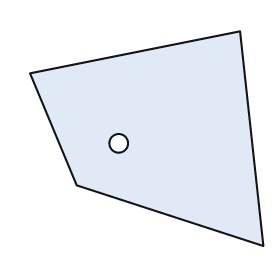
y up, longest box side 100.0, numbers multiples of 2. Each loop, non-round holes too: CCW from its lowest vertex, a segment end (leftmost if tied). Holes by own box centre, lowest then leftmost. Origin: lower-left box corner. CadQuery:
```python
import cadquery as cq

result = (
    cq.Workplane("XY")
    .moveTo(100.0, 0.0)
    .lineTo(90.0, 92.0)
    .lineTo(0.0, 74.0)
    .lineTo(20.0, 26.0)
    .close()
    .moveTo(38.0, 44.0)
    .circle(4.0)
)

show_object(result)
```